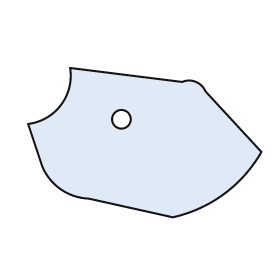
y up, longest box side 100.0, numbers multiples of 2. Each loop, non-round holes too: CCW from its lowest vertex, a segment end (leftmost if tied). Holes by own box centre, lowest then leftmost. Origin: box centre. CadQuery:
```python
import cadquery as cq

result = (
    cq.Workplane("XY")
    .moveTo(12.0, -32.0)
    .threePointArc((34.0, -22.0), (50.0, -4.0))
    .lineTo(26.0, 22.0)
    .threePointArc((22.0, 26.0), (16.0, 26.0))
    .lineTo(-32.0, 32.0)
    .threePointArc((-36.0, 16.0), (-50.0, 8.0))
    .lineTo(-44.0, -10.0)
    .threePointArc((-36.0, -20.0), (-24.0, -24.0))
    .close()
    .moveTo(-10.0, 10.0)
    .circle(4.0)
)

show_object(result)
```